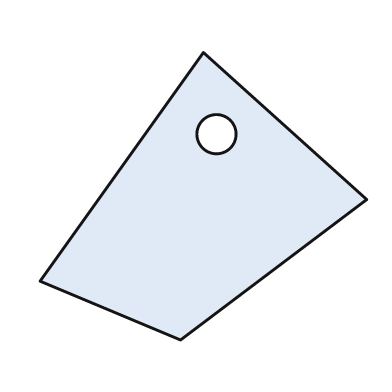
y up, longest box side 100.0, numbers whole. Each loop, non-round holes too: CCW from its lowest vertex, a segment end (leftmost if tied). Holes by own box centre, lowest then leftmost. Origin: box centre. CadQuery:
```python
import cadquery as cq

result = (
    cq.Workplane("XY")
    .moveTo(-7.0, -44.0)
    .lineTo(50.0, -1.0)
    .lineTo(0.0, 44.0)
    .lineTo(-50.0, -26.0)
    .close()
    .moveTo(4.0, 19.0)
    .circle(6.0)
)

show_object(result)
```